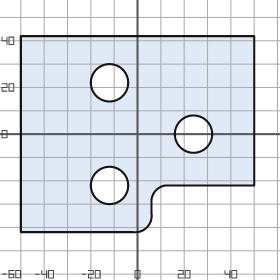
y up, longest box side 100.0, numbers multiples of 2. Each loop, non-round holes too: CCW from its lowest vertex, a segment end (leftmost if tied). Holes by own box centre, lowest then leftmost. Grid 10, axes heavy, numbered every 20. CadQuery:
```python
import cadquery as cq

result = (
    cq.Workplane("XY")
    .moveTo(-50.0, -42.0)
    .lineTo(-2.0, -42.0)
    .threePointArc((4.0, -40.0), (6.0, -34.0))
    .lineTo(6.0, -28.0)
    .threePointArc((8.0, -24.0), (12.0, -22.0))
    .lineTo(50.0, -22.0)
    .lineTo(50.0, 42.0)
    .lineTo(-50.0, 42.0)
    .close()
    .moveTo(-12.0, -22.0)
    .circle(8.0)
    .moveTo(24.0, 0.0)
    .circle(8.0)
    .moveTo(-12.0, 22.0)
    .circle(8.0)
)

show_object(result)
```